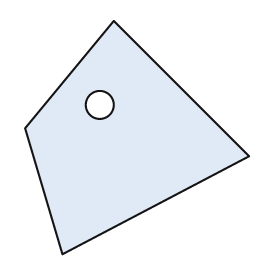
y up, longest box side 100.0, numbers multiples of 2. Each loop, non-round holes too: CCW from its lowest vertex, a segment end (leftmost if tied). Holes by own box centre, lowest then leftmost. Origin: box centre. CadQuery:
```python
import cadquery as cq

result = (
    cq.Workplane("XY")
    .moveTo(-32.0, -50.0)
    .lineTo(48.0, -8.0)
    .lineTo(-10.0, 50.0)
    .lineTo(-48.0, 4.0)
    .close()
    .moveTo(-16.0, 14.0)
    .circle(6.0)
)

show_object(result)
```